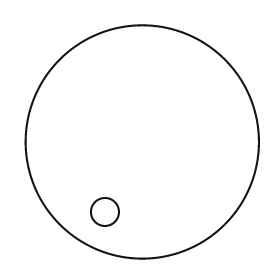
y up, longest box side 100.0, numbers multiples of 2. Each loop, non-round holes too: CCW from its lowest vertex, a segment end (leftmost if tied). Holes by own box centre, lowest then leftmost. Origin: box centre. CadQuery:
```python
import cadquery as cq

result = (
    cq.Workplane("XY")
    .moveTo(0.0, 0.0)
    .circle(50.0)
    .moveTo(-16.0, -30.0)
    .circle(6.0)
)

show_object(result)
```